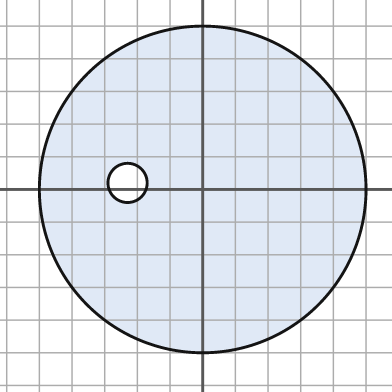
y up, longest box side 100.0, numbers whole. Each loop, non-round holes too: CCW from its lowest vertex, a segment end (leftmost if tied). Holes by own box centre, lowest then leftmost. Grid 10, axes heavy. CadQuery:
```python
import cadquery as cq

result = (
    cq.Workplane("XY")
    .moveTo(0.0, 0.0)
    .circle(50.0)
    .moveTo(-23.0, 2.0)
    .circle(6.0)
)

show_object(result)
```